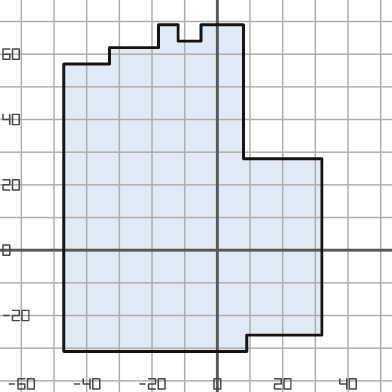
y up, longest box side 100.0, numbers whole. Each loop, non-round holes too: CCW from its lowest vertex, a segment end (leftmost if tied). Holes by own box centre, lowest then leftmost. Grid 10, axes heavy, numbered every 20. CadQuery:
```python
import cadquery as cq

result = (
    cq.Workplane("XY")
    .moveTo(-47.0, -31.0)
    .lineTo(9.0, -31.0)
    .lineTo(9.0, -26.0)
    .lineTo(32.0, -26.0)
    .lineTo(32.0, 28.0)
    .lineTo(8.0, 28.0)
    .lineTo(8.0, 69.0)
    .lineTo(-5.0, 69.0)
    .lineTo(-5.0, 64.0)
    .lineTo(-12.0, 64.0)
    .lineTo(-12.0, 69.0)
    .lineTo(-18.0, 69.0)
    .lineTo(-18.0, 62.0)
    .lineTo(-33.0, 62.0)
    .lineTo(-33.0, 57.0)
    .lineTo(-47.0, 57.0)
    .close()
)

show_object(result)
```